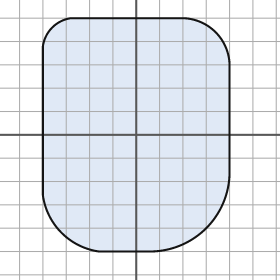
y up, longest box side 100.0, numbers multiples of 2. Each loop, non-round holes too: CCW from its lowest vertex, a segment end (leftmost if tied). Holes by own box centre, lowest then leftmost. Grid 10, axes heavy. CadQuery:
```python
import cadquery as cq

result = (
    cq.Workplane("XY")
    .moveTo(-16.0, -50.0)
    .lineTo(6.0, -50.0)
    .threePointArc((30.0, -40.0), (40.0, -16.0))
    .lineTo(40.0, 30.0)
    .threePointArc((34.0, 44.0), (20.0, 50.0))
    .lineTo(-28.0, 50.0)
    .threePointArc((-36.0, 46.0), (-40.0, 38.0))
    .lineTo(-40.0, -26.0)
    .threePointArc((-32.0, -42.0), (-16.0, -50.0))
    .close()
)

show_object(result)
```